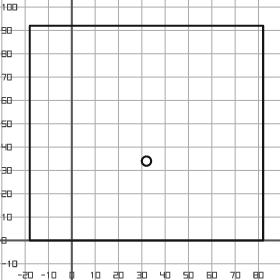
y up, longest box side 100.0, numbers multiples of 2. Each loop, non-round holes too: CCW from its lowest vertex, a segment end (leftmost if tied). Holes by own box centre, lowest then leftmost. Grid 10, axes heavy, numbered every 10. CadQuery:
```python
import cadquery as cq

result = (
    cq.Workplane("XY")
    .moveTo(-18.0, 0.0)
    .lineTo(82.0, 0.0)
    .lineTo(82.0, 92.0)
    .lineTo(-18.0, 92.0)
    .close()
    .moveTo(32.0, 34.0)
    .circle(2.0)
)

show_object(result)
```